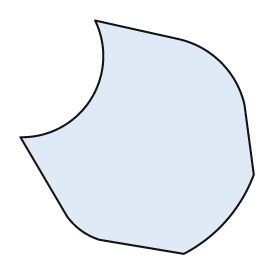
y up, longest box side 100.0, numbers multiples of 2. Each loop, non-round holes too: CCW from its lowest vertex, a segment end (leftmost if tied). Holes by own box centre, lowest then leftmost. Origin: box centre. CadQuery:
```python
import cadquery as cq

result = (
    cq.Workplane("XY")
    .moveTo(20.0, -50.0)
    .threePointArc((38.0, -36.0), (50.0, -16.0))
    .lineTo(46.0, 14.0)
    .threePointArc((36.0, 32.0), (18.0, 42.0))
    .lineTo(-18.0, 50.0)
    .threePointArc((-20.0, 16.0), (-50.0, 0.0))
    .lineTo(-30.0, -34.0)
    .threePointArc((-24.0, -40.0), (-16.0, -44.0))
    .close()
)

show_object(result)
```